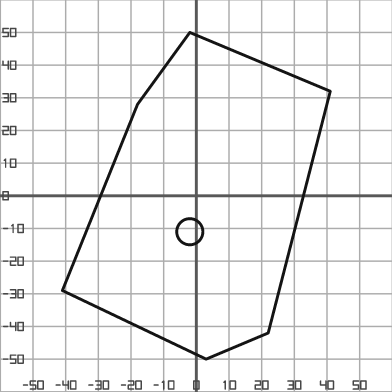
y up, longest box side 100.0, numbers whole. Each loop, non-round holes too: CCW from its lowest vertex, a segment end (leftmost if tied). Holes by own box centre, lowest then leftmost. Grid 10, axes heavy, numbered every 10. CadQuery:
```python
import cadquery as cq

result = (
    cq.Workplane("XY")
    .moveTo(3.0, -50.0)
    .lineTo(22.0, -42.0)
    .lineTo(41.0, 32.0)
    .lineTo(-2.0, 50.0)
    .lineTo(-18.0, 28.0)
    .lineTo(-41.0, -29.0)
    .close()
    .moveTo(-2.0, -11.0)
    .circle(4.0)
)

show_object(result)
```